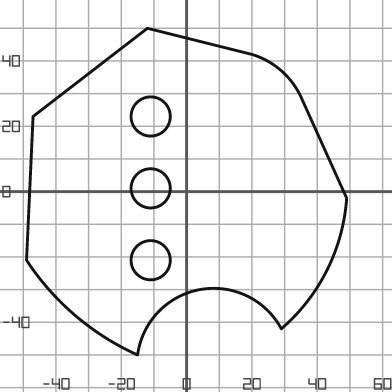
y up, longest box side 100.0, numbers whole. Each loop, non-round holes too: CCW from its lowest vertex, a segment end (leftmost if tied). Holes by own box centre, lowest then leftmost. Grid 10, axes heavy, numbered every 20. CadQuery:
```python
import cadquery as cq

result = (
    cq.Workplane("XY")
    .moveTo(-15.0, -50.0)
    .threePointArc((4.0, -30.0), (29.0, -42.0))
    .threePointArc((43.0, -24.0), (49.0, -2.0))
    .lineTo(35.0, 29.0)
    .threePointArc((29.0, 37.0), (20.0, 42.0))
    .lineTo(-12.0, 50.0)
    .lineTo(-47.0, 23.0)
    .lineTo(-49.0, -21.0)
    .threePointArc((-34.0, -38.0), (-15.0, -50.0))
    .close()
    .moveTo(-11.0, -21.0)
    .circle(6.0)
    .moveTo(-11.0, 1.0)
    .circle(6.0)
    .moveTo(-11.0, 23.0)
    .circle(6.0)
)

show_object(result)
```